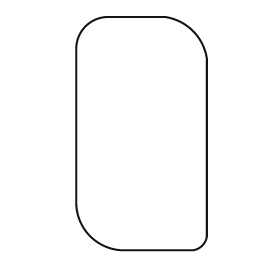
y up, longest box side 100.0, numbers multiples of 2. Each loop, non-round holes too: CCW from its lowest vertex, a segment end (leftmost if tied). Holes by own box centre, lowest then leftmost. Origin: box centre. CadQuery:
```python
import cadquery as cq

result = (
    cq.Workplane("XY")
    .moveTo(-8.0, -50.0)
    .lineTo(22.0, -50.0)
    .threePointArc((26.0, -48.0), (28.0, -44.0))
    .lineTo(28.0, 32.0)
    .threePointArc((22.0, 44.0), (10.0, 50.0))
    .lineTo(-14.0, 50.0)
    .threePointArc((-24.0, 46.0), (-28.0, 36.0))
    .lineTo(-28.0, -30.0)
    .threePointArc((-22.0, -44.0), (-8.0, -50.0))
    .close()
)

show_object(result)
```